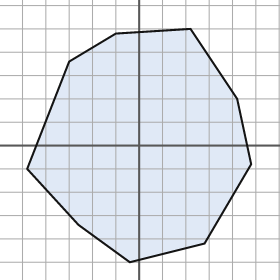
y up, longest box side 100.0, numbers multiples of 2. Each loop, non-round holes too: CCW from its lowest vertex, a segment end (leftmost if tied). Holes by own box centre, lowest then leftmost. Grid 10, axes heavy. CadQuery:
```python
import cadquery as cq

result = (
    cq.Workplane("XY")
    .moveTo(-4.0, -50.0)
    .lineTo(28.0, -42.0)
    .lineTo(48.0, -8.0)
    .lineTo(42.0, 20.0)
    .lineTo(22.0, 50.0)
    .lineTo(-10.0, 48.0)
    .lineTo(-30.0, 36.0)
    .lineTo(-48.0, -10.0)
    .lineTo(-26.0, -34.0)
    .close()
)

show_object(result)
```